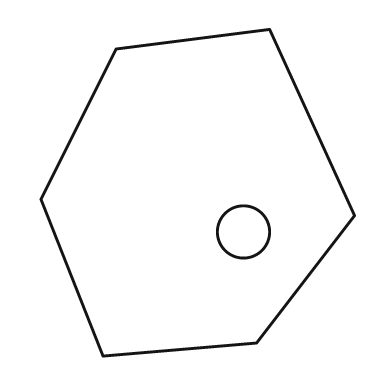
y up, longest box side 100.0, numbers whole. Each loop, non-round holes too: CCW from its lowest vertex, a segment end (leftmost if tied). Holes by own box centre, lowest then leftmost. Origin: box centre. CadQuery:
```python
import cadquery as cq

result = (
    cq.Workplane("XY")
    .moveTo(-29.0, -50.0)
    .lineTo(18.0, -46.0)
    .lineTo(48.0, -7.0)
    .lineTo(22.0, 50.0)
    .lineTo(-25.0, 44.0)
    .lineTo(-48.0, -2.0)
    .close()
    .moveTo(14.0, -12.0)
    .circle(8.0)
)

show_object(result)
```